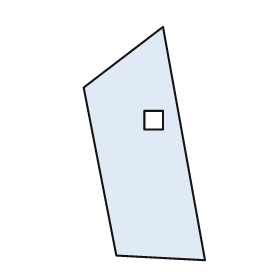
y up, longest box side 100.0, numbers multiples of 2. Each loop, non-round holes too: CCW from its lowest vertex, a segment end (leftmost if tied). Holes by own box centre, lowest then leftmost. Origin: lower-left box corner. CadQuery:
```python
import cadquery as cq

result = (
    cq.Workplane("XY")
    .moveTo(52.0, 0.0)
    .lineTo(34.0, 100.0)
    .lineTo(0.0, 74.0)
    .lineTo(14.0, 2.0)
    .close()
    .moveTo(26.0, 56.0)
    .lineTo(34.0, 56.0)
    .lineTo(34.0, 64.0)
    .lineTo(26.0, 64.0)
    .close()
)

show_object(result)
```